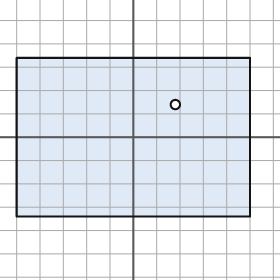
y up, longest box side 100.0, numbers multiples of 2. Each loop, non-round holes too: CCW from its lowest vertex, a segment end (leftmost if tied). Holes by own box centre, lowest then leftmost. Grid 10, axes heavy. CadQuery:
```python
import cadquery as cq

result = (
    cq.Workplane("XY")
    .moveTo(-50.0, -34.0)
    .lineTo(50.0, -34.0)
    .lineTo(50.0, 34.0)
    .lineTo(-50.0, 34.0)
    .close()
    .moveTo(18.0, 14.0)
    .circle(2.0)
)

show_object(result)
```